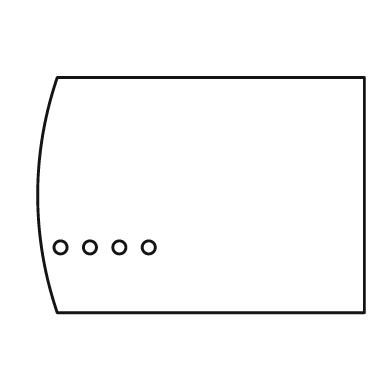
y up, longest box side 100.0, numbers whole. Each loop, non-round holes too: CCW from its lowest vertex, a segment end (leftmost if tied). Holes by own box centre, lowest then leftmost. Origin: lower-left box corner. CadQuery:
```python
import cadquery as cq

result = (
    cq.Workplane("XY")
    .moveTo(6.0, 0.0)
    .lineTo(100.0, 0.0)
    .lineTo(100.0, 72.0)
    .lineTo(6.0, 72.0)
    .threePointArc((0.0, 36.0), (6.0, 0.0))
    .close()
    .moveTo(7.0, 20.0)
    .circle(2.0)
    .moveTo(16.0, 20.0)
    .circle(2.0)
    .moveTo(25.0, 20.0)
    .circle(2.0)
    .moveTo(34.0, 20.0)
    .circle(2.0)
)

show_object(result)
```